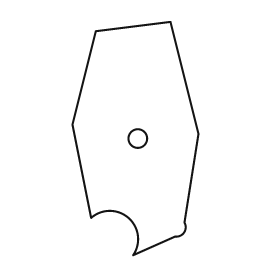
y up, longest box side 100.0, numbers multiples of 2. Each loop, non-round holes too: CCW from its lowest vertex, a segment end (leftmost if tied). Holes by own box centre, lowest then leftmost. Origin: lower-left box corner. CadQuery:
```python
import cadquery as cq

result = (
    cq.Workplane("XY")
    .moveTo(26.0, 0.0)
    .lineTo(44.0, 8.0)
    .threePointArc((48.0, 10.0), (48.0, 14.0))
    .lineTo(54.0, 52.0)
    .lineTo(42.0, 100.0)
    .lineTo(10.0, 96.0)
    .lineTo(0.0, 56.0)
    .lineTo(8.0, 16.0)
    .threePointArc((24.0, 16.0), (26.0, 0.0))
    .close()
    .moveTo(28.0, 50.0)
    .circle(4.0)
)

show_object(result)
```